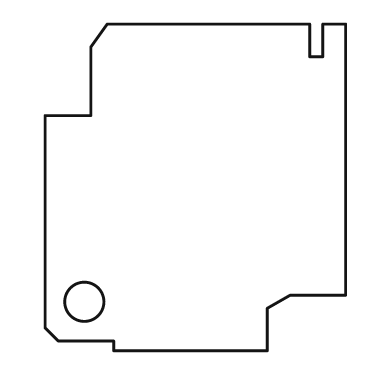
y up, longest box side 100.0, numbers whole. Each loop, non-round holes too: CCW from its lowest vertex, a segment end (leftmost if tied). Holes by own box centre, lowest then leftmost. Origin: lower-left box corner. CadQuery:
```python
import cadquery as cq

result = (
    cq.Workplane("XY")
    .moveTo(21.0, 0.0)
    .lineTo(68.0, 0.0)
    .lineTo(68.0, 13.0)
    .lineTo(75.0, 17.0)
    .lineTo(92.0, 17.0)
    .lineTo(92.0, 100.0)
    .lineTo(85.0, 100.0)
    .lineTo(85.0, 90.0)
    .lineTo(81.0, 90.0)
    .lineTo(81.0, 100.0)
    .lineTo(19.0, 100.0)
    .lineTo(14.0, 93.0)
    .lineTo(14.0, 72.0)
    .lineTo(0.0, 72.0)
    .lineTo(0.0, 7.0)
    .lineTo(4.0, 3.0)
    .lineTo(21.0, 3.0)
    .close()
    .moveTo(12.0, 15.0)
    .circle(6.0)
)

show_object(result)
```